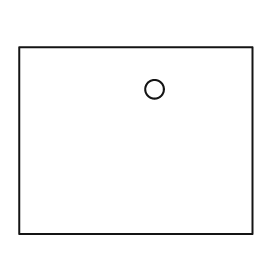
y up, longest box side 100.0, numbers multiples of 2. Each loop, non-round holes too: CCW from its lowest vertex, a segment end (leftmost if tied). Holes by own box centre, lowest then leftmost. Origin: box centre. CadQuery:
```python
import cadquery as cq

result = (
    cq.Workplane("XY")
    .moveTo(-50.0, -40.0)
    .lineTo(50.0, -40.0)
    .lineTo(50.0, 40.0)
    .lineTo(-50.0, 40.0)
    .close()
    .moveTo(8.0, 22.0)
    .circle(4.0)
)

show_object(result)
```